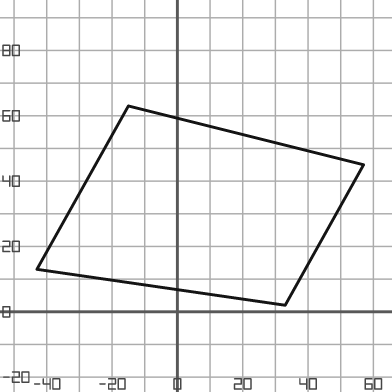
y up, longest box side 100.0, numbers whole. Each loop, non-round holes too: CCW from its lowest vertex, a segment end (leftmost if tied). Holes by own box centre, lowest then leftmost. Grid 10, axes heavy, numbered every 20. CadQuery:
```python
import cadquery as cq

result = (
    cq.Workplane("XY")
    .moveTo(33.0, 2.0)
    .lineTo(57.0, 45.0)
    .lineTo(-15.0, 63.0)
    .lineTo(-43.0, 13.0)
    .close()
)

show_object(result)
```